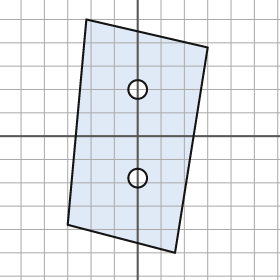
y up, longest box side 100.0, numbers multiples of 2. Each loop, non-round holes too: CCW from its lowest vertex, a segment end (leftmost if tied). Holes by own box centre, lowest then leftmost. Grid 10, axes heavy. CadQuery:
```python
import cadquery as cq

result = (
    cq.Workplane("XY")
    .moveTo(16.0, -50.0)
    .lineTo(30.0, 38.0)
    .lineTo(-22.0, 50.0)
    .lineTo(-30.0, -38.0)
    .close()
    .moveTo(0.0, -18.0)
    .circle(4.0)
    .moveTo(0.0, 20.0)
    .circle(4.0)
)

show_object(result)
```